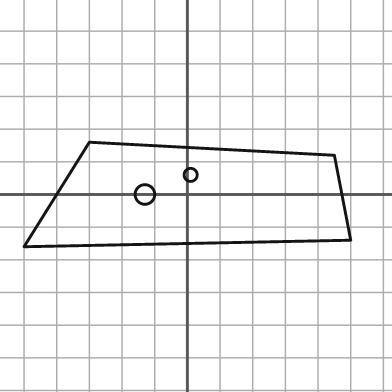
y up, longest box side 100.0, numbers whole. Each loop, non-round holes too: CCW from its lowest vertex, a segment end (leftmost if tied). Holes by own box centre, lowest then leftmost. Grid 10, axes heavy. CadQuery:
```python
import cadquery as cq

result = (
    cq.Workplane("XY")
    .moveTo(-50.0, -16.0)
    .lineTo(50.0, -14.0)
    .lineTo(45.0, 12.0)
    .lineTo(-30.0, 16.0)
    .close()
    .moveTo(-13.0, 0.0)
    .circle(3.0)
    .moveTo(1.0, 6.0)
    .circle(2.0)
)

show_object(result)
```